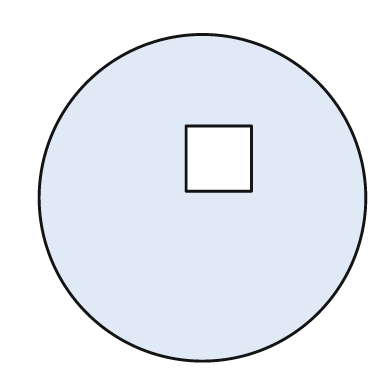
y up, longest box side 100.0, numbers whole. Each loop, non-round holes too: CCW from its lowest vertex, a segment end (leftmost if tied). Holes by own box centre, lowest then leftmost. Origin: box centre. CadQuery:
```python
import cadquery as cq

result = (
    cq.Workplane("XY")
    .moveTo(0.0, 0.0)
    .circle(50.0)
    .moveTo(-5.0, 2.0)
    .lineTo(15.0, 2.0)
    .lineTo(15.0, 22.0)
    .lineTo(-5.0, 22.0)
    .close()
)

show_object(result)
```